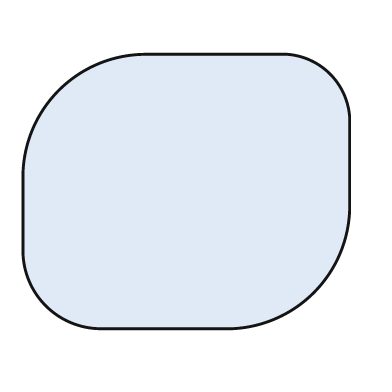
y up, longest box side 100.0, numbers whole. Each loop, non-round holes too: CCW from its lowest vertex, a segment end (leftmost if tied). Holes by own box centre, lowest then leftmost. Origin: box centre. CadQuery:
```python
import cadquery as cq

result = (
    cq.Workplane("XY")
    .moveTo(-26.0, -42.0)
    .lineTo(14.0, -42.0)
    .threePointArc((39.0, -31.0), (50.0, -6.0))
    .lineTo(50.0, 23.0)
    .threePointArc((44.0, 36.0), (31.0, 42.0))
    .lineTo(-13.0, 42.0)
    .threePointArc((-39.0, 31.0), (-50.0, 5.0))
    .lineTo(-50.0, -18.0)
    .threePointArc((-43.0, -35.0), (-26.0, -42.0))
    .close()
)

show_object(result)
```